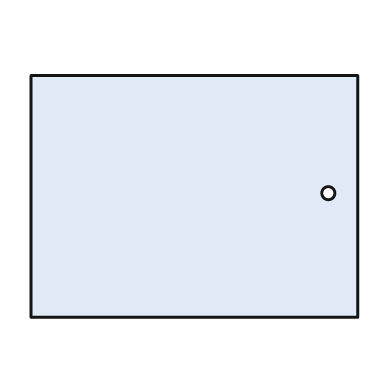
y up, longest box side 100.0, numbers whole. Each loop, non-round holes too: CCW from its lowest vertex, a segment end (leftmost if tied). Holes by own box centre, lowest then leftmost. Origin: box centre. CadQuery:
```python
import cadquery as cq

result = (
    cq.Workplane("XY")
    .moveTo(-50.0, -37.0)
    .lineTo(50.0, -37.0)
    .lineTo(50.0, 37.0)
    .lineTo(-50.0, 37.0)
    .close()
    .moveTo(41.0, 1.0)
    .circle(2.0)
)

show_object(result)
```